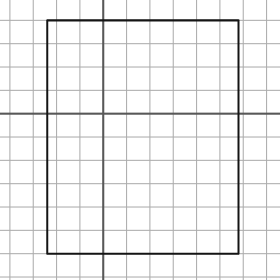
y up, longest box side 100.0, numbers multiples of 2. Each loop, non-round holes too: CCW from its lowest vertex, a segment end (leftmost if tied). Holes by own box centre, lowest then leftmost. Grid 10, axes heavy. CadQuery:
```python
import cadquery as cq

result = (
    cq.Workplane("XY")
    .moveTo(-24.0, -60.0)
    .lineTo(58.0, -60.0)
    .lineTo(58.0, 40.0)
    .lineTo(-24.0, 40.0)
    .close()
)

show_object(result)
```